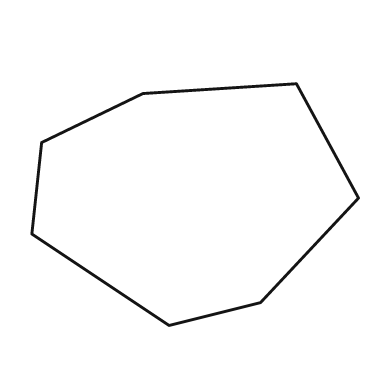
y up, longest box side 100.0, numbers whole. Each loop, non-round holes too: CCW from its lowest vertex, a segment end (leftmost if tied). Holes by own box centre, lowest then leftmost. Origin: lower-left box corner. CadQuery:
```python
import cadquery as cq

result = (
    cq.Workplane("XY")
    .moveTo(42.0, 0.0)
    .lineTo(70.0, 7.0)
    .lineTo(100.0, 39.0)
    .lineTo(81.0, 74.0)
    .lineTo(34.0, 71.0)
    .lineTo(3.0, 56.0)
    .lineTo(0.0, 28.0)
    .close()
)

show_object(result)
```